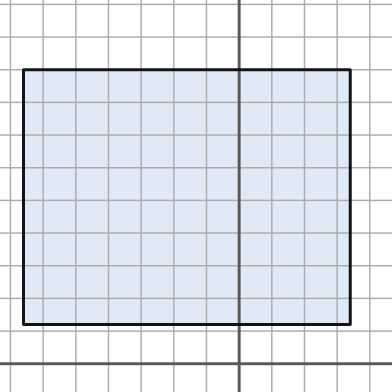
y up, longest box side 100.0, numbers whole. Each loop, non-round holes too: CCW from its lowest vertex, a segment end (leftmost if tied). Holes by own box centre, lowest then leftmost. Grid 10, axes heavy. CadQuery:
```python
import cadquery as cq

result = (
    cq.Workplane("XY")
    .moveTo(-66.0, 12.0)
    .lineTo(34.0, 12.0)
    .lineTo(34.0, 90.0)
    .lineTo(-66.0, 90.0)
    .close()
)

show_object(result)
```